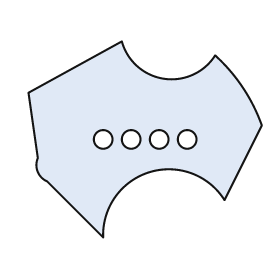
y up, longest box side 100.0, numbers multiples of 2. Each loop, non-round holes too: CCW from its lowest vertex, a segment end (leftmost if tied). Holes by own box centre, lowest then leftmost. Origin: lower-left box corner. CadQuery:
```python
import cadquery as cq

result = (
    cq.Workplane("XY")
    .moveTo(32.0, 0.0)
    .threePointArc((52.0, 28.0), (84.0, 16.0))
    .lineTo(100.0, 48.0)
    .threePointArc((92.0, 64.0), (80.0, 78.0))
    .threePointArc((58.0, 68.0), (40.0, 84.0))
    .lineTo(0.0, 62.0)
    .lineTo(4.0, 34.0)
    .threePointArc((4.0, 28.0), (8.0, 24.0))
    .close()
    .moveTo(32.0, 42.0)
    .circle(4.0)
    .moveTo(44.0, 42.0)
    .circle(4.0)
    .moveTo(56.0, 42.0)
    .circle(4.0)
    .moveTo(68.0, 42.0)
    .circle(4.0)
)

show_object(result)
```